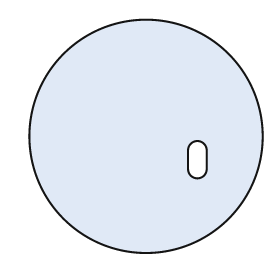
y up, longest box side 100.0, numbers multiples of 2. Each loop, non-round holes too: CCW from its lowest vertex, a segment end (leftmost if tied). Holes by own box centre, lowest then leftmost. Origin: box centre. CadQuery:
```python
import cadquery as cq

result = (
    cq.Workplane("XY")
    .moveTo(0.0, 0.0)
    .circle(50.0)
    .moveTo(18.0, -14.0)
    .threePointArc((22.0, -18.0), (26.0, -14.0))
    .lineTo(26.0, -6.0)
    .threePointArc((22.0, -2.0), (18.0, -6.0))
    .close()
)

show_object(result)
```